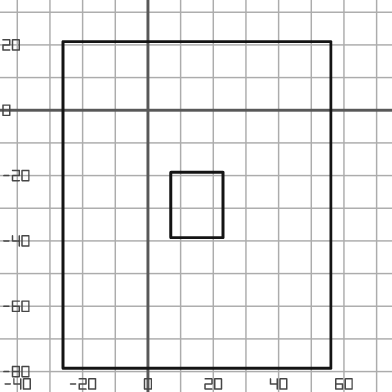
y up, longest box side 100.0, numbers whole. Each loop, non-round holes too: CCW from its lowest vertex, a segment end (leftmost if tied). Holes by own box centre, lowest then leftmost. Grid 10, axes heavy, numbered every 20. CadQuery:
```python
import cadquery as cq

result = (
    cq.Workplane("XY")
    .moveTo(-26.0, -79.0)
    .lineTo(56.0, -79.0)
    .lineTo(56.0, 21.0)
    .lineTo(-26.0, 21.0)
    .close()
    .moveTo(7.0, -39.0)
    .lineTo(23.0, -39.0)
    .lineTo(23.0, -19.0)
    .lineTo(7.0, -19.0)
    .close()
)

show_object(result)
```